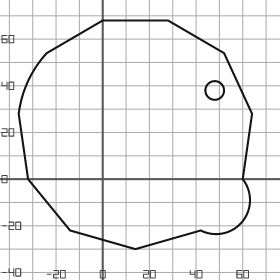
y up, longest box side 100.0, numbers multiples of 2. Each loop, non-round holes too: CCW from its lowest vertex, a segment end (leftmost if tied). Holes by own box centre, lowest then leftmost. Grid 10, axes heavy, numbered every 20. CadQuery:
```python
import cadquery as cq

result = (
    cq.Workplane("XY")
    .moveTo(14.0, -30.0)
    .lineTo(42.0, -22.0)
    .threePointArc((60.0, -18.0), (60.0, 0.0))
    .lineTo(64.0, 28.0)
    .lineTo(52.0, 54.0)
    .lineTo(28.0, 68.0)
    .lineTo(0.0, 68.0)
    .lineTo(-24.0, 54.0)
    .threePointArc((-32.0, 42.0), (-36.0, 28.0))
    .lineTo(-32.0, 0.0)
    .lineTo(-14.0, -22.0)
    .close()
    .moveTo(48.0, 38.0)
    .circle(4.0)
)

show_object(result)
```